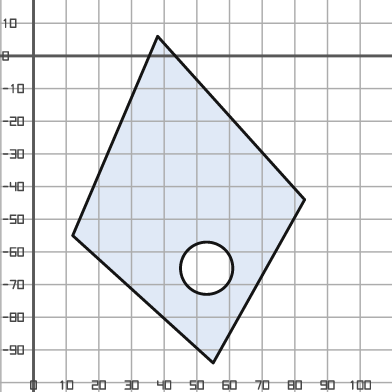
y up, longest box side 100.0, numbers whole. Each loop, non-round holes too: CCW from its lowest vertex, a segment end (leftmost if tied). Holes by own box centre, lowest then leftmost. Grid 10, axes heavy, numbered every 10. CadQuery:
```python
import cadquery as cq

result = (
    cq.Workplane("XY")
    .moveTo(55.0, -94.0)
    .lineTo(83.0, -44.0)
    .lineTo(38.0, 6.0)
    .lineTo(12.0, -55.0)
    .close()
    .moveTo(53.0, -65.0)
    .circle(8.0)
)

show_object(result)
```